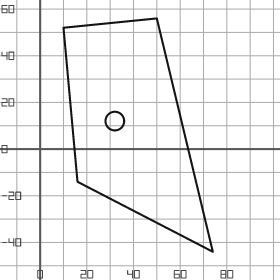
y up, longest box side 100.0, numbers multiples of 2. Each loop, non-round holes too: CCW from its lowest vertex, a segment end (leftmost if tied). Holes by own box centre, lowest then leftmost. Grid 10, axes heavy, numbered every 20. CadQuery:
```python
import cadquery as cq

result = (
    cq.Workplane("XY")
    .moveTo(74.0, -44.0)
    .lineTo(50.0, 56.0)
    .lineTo(10.0, 52.0)
    .lineTo(16.0, -14.0)
    .close()
    .moveTo(32.0, 12.0)
    .circle(4.0)
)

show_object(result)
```